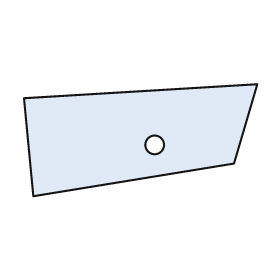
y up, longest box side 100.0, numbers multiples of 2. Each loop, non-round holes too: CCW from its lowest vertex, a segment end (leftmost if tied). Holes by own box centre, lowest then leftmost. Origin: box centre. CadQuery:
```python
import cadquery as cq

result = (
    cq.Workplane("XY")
    .moveTo(-46.0, -24.0)
    .lineTo(40.0, -10.0)
    .lineTo(50.0, 24.0)
    .lineTo(-50.0, 18.0)
    .close()
    .moveTo(6.0, -2.0)
    .circle(4.0)
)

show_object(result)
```